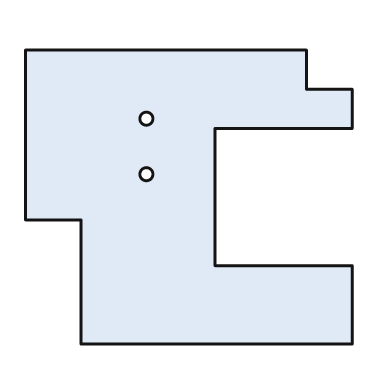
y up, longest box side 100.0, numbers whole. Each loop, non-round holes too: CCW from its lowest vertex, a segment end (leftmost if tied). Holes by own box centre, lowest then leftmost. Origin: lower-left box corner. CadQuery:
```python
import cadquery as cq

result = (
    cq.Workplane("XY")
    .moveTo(17.0, 0.0)
    .lineTo(100.0, 0.0)
    .lineTo(100.0, 24.0)
    .lineTo(58.0, 24.0)
    .lineTo(58.0, 66.0)
    .lineTo(100.0, 66.0)
    .lineTo(100.0, 78.0)
    .lineTo(86.0, 78.0)
    .lineTo(86.0, 90.0)
    .lineTo(0.0, 90.0)
    .lineTo(0.0, 38.0)
    .lineTo(17.0, 38.0)
    .close()
    .moveTo(37.0, 52.0)
    .circle(2.0)
    .moveTo(37.0, 69.0)
    .circle(2.0)
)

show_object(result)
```